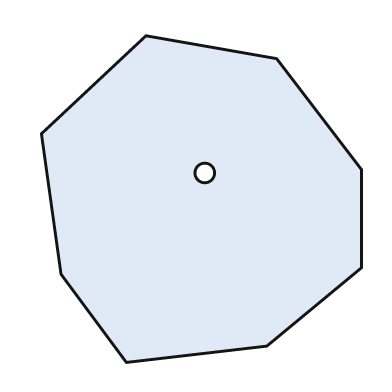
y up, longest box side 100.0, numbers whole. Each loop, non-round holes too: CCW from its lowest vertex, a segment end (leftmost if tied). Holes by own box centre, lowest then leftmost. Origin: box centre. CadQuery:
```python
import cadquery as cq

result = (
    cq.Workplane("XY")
    .moveTo(-23.0, -50.0)
    .lineTo(20.0, -45.0)
    .lineTo(49.0, -21.0)
    .lineTo(49.0, 9.0)
    .lineTo(23.0, 43.0)
    .lineTo(-17.0, 50.0)
    .lineTo(-49.0, 20.0)
    .lineTo(-43.0, -23.0)
    .close()
    .moveTo(1.0, 8.0)
    .circle(3.0)
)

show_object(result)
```